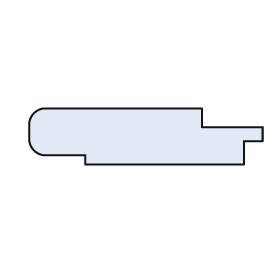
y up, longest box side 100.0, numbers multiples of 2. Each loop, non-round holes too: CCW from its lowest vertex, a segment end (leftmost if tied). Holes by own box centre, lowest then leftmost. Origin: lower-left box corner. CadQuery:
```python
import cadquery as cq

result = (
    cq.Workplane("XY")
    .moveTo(24.0, 0.0)
    .lineTo(92.0, 0.0)
    .lineTo(92.0, 10.0)
    .lineTo(100.0, 10.0)
    .lineTo(100.0, 16.0)
    .lineTo(74.0, 16.0)
    .lineTo(74.0, 24.0)
    .lineTo(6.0, 24.0)
    .threePointArc((2.0, 22.0), (0.0, 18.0))
    .lineTo(0.0, 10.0)
    .threePointArc((2.0, 6.0), (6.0, 4.0))
    .lineTo(24.0, 4.0)
    .close()
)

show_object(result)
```